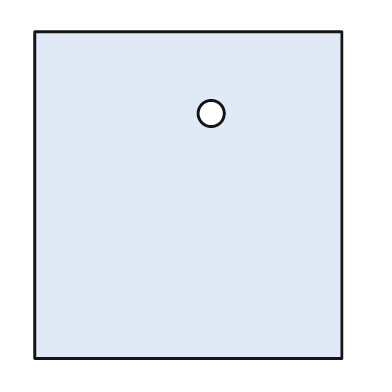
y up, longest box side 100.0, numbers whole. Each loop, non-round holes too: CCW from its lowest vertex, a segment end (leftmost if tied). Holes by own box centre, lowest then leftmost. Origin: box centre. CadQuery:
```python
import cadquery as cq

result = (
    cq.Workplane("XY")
    .moveTo(-47.0, -50.0)
    .lineTo(47.0, -50.0)
    .lineTo(47.0, 50.0)
    .lineTo(-47.0, 50.0)
    .close()
    .moveTo(7.0, 25.0)
    .circle(4.0)
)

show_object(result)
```